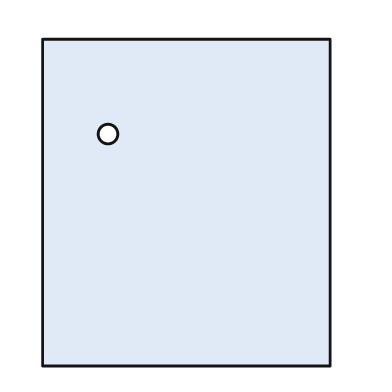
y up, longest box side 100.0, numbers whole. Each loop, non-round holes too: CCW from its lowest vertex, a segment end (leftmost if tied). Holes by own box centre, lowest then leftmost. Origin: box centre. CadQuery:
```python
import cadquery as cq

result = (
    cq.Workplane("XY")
    .moveTo(-44.0, -50.0)
    .lineTo(44.0, -50.0)
    .lineTo(44.0, 50.0)
    .lineTo(-44.0, 50.0)
    .close()
    .moveTo(-24.0, 21.0)
    .circle(3.0)
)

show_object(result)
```